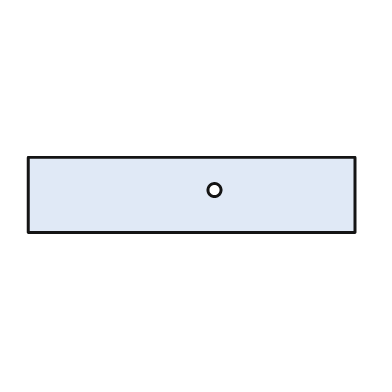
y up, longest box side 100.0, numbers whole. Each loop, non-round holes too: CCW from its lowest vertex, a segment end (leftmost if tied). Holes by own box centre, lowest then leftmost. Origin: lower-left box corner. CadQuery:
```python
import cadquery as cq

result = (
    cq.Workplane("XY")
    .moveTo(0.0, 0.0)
    .lineTo(100.0, 0.0)
    .lineTo(100.0, 23.0)
    .lineTo(0.0, 23.0)
    .close()
    .moveTo(57.0, 13.0)
    .circle(2.0)
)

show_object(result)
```